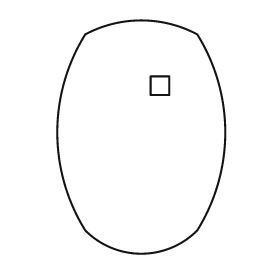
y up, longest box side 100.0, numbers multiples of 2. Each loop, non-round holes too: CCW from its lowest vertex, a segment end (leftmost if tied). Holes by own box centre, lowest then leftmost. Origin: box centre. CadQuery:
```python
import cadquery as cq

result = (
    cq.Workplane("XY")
    .moveTo(-24.0, -40.0)
    .threePointArc((0.0, -50.0), (24.0, -40.0))
    .threePointArc((36.0, 2.0), (24.0, 44.0))
    .threePointArc((0.0, 50.0), (-24.0, 44.0))
    .threePointArc((-36.0, 2.0), (-24.0, -40.0))
    .close()
    .moveTo(4.0, 18.0)
    .lineTo(12.0, 18.0)
    .lineTo(12.0, 26.0)
    .lineTo(4.0, 26.0)
    .close()
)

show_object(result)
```